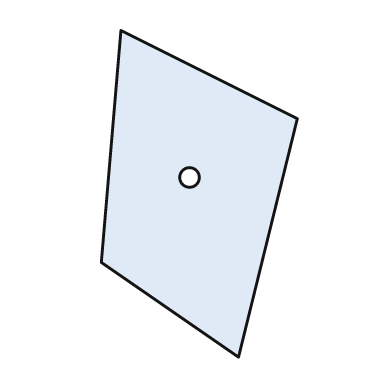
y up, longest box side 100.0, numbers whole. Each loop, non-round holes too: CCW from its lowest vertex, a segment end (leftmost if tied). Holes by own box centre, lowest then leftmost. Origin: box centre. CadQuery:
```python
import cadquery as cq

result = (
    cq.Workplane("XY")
    .moveTo(12.0, -50.0)
    .lineTo(30.0, 23.0)
    .lineTo(-24.0, 50.0)
    .lineTo(-30.0, -21.0)
    .close()
    .moveTo(-3.0, 5.0)
    .circle(3.0)
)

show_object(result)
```